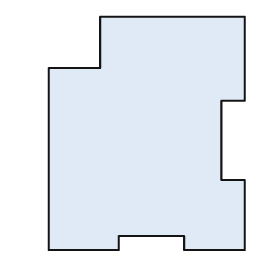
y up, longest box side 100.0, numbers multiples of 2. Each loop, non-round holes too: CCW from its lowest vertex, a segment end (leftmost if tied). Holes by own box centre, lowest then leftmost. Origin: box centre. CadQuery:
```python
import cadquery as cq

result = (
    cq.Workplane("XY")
    .moveTo(-42.0, -50.0)
    .lineTo(-12.0, -50.0)
    .lineTo(-12.0, -44.0)
    .lineTo(16.0, -44.0)
    .lineTo(16.0, -50.0)
    .lineTo(42.0, -50.0)
    .lineTo(42.0, -20.0)
    .lineTo(32.0, -20.0)
    .lineTo(32.0, 14.0)
    .lineTo(42.0, 14.0)
    .lineTo(42.0, 50.0)
    .lineTo(-20.0, 50.0)
    .lineTo(-20.0, 28.0)
    .lineTo(-42.0, 28.0)
    .close()
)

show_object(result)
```